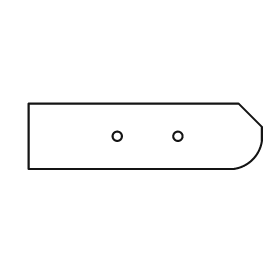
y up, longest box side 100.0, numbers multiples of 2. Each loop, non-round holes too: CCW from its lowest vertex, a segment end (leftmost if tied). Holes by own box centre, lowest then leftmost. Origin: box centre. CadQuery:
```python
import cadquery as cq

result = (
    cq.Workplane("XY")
    .moveTo(-50.0, -14.0)
    .lineTo(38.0, -14.0)
    .threePointArc((46.0, -10.0), (50.0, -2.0))
    .lineTo(50.0, 4.0)
    .lineTo(40.0, 14.0)
    .lineTo(-50.0, 14.0)
    .close()
    .moveTo(-12.0, 0.0)
    .circle(2.0)
    .moveTo(14.0, 0.0)
    .circle(2.0)
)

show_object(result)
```